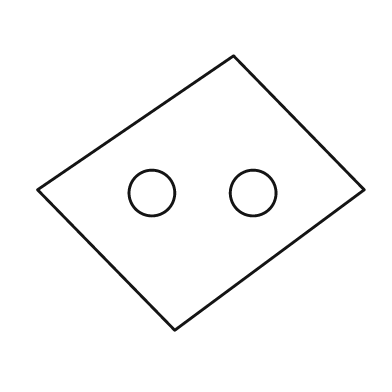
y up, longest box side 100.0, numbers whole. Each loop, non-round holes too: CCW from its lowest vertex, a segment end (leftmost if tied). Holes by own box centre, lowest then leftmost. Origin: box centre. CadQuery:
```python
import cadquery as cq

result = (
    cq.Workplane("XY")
    .moveTo(-8.0, -42.0)
    .lineTo(50.0, 1.0)
    .lineTo(10.0, 42.0)
    .lineTo(-50.0, 1.0)
    .close()
    .moveTo(-15.0, 0.0)
    .circle(7.0)
    .moveTo(16.0, 0.0)
    .circle(7.0)
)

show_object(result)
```